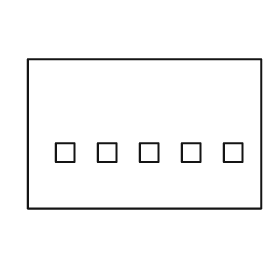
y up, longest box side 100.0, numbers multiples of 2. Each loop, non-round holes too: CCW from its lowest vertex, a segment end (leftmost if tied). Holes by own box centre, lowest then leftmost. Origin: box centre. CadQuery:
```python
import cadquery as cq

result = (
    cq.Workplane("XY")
    .moveTo(-50.0, -32.0)
    .lineTo(50.0, -32.0)
    .lineTo(50.0, 32.0)
    .lineTo(-50.0, 32.0)
    .close()
    .moveTo(-38.0, -12.0)
    .lineTo(-30.0, -12.0)
    .lineTo(-30.0, -4.0)
    .lineTo(-38.0, -4.0)
    .close()
    .moveTo(-20.0, -12.0)
    .lineTo(-12.0, -12.0)
    .lineTo(-12.0, -4.0)
    .lineTo(-20.0, -4.0)
    .close()
    .moveTo(-2.0, -12.0)
    .lineTo(6.0, -12.0)
    .lineTo(6.0, -4.0)
    .lineTo(-2.0, -4.0)
    .close()
    .moveTo(16.0, -12.0)
    .lineTo(24.0, -12.0)
    .lineTo(24.0, -4.0)
    .lineTo(16.0, -4.0)
    .close()
    .moveTo(34.0, -12.0)
    .lineTo(42.0, -12.0)
    .lineTo(42.0, -4.0)
    .lineTo(34.0, -4.0)
    .close()
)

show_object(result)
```